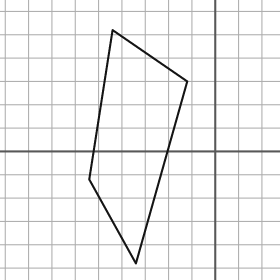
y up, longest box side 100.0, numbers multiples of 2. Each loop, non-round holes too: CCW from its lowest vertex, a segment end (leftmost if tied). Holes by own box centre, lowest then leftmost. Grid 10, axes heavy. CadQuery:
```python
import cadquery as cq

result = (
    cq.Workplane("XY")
    .moveTo(-34.0, -48.0)
    .lineTo(-12.0, 30.0)
    .lineTo(-44.0, 52.0)
    .lineTo(-54.0, -12.0)
    .close()
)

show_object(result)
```